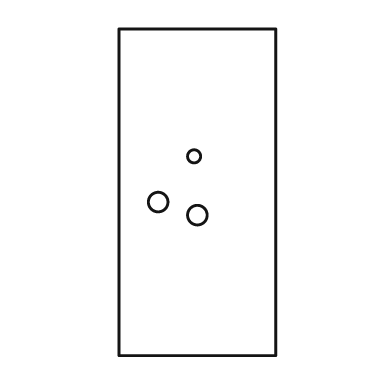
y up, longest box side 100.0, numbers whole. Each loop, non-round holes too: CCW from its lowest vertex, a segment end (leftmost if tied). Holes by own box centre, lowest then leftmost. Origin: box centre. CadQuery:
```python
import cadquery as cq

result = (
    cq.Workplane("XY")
    .moveTo(-24.0, -50.0)
    .lineTo(24.0, -50.0)
    .lineTo(24.0, 50.0)
    .lineTo(-24.0, 50.0)
    .close()
    .moveTo(0.0, -7.0)
    .circle(3.0)
    .moveTo(-12.0, -3.0)
    .circle(3.0)
    .moveTo(-1.0, 11.0)
    .circle(2.0)
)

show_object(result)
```